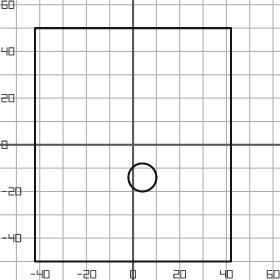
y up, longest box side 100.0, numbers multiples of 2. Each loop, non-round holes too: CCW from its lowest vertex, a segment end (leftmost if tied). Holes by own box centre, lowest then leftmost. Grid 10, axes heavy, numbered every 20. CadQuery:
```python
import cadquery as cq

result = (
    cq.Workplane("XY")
    .moveTo(-42.0, -50.0)
    .lineTo(42.0, -50.0)
    .lineTo(42.0, 50.0)
    .lineTo(-42.0, 50.0)
    .close()
    .moveTo(4.0, -14.0)
    .circle(6.0)
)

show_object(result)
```